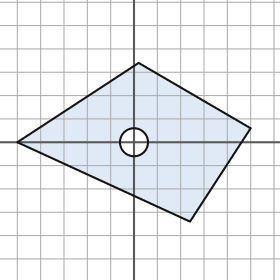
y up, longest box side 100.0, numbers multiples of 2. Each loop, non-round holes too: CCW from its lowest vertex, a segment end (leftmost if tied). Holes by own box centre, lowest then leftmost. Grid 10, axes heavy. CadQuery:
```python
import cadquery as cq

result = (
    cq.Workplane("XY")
    .moveTo(24.0, -34.0)
    .lineTo(50.0, 6.0)
    .lineTo(2.0, 34.0)
    .lineTo(-50.0, 0.0)
    .close()
    .moveTo(0.0, 0.0)
    .circle(6.0)
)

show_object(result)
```